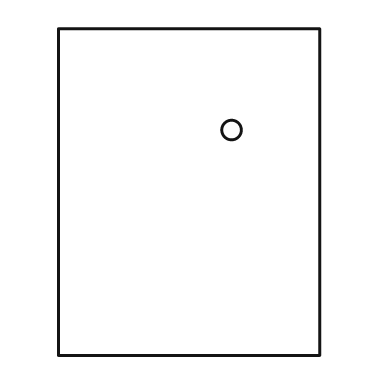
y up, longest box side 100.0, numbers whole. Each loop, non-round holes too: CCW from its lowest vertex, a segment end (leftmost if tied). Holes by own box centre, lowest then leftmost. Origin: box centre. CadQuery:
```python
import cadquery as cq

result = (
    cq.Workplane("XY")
    .moveTo(-40.0, -50.0)
    .lineTo(40.0, -50.0)
    .lineTo(40.0, 50.0)
    .lineTo(-40.0, 50.0)
    .close()
    .moveTo(13.0, 19.0)
    .circle(3.0)
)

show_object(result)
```